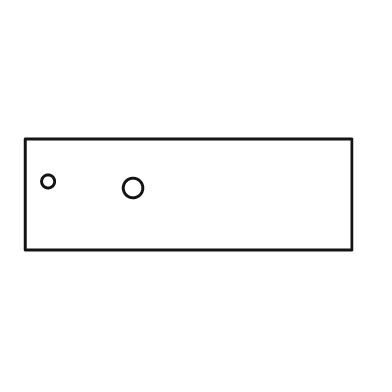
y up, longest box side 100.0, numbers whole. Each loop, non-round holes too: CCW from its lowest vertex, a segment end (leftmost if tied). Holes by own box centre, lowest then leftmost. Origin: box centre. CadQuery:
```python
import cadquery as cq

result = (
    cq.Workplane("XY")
    .moveTo(-50.0, -17.0)
    .lineTo(50.0, -17.0)
    .lineTo(50.0, 17.0)
    .lineTo(-50.0, 17.0)
    .close()
    .moveTo(-17.0, 2.0)
    .circle(3.0)
    .moveTo(-43.0, 4.0)
    .circle(2.0)
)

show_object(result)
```